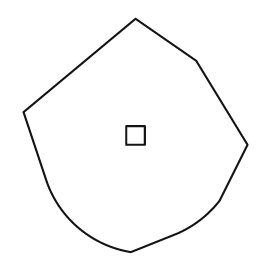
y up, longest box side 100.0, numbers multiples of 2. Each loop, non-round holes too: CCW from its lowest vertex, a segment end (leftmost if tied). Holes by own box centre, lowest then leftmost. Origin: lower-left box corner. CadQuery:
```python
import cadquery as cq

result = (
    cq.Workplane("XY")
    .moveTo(46.0, 0.0)
    .lineTo(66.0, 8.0)
    .threePointArc((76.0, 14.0), (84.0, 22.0))
    .lineTo(96.0, 46.0)
    .lineTo(74.0, 82.0)
    .lineTo(48.0, 100.0)
    .lineTo(0.0, 60.0)
    .lineTo(10.0, 30.0)
    .threePointArc((24.0, 10.0), (46.0, 0.0))
    .close()
    .moveTo(44.0, 46.0)
    .lineTo(52.0, 46.0)
    .lineTo(52.0, 54.0)
    .lineTo(44.0, 54.0)
    .close()
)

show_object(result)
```